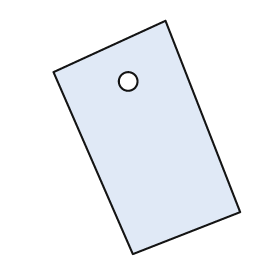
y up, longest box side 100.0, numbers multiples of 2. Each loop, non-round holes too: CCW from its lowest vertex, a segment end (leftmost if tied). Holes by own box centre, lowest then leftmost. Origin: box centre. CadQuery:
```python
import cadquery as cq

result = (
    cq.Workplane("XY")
    .moveTo(-6.0, -50.0)
    .lineTo(40.0, -32.0)
    .lineTo(8.0, 50.0)
    .lineTo(-40.0, 28.0)
    .close()
    .moveTo(-8.0, 24.0)
    .circle(4.0)
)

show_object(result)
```